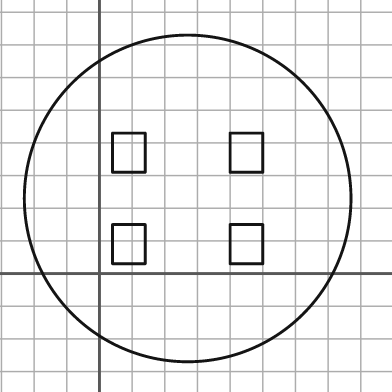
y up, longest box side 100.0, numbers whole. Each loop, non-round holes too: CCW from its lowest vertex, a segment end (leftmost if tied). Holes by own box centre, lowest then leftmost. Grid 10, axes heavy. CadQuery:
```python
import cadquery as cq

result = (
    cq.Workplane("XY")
    .moveTo(27.0, 23.0)
    .circle(50.0)
    .moveTo(4.0, 3.0)
    .lineTo(14.0, 3.0)
    .lineTo(14.0, 15.0)
    .lineTo(4.0, 15.0)
    .close()
    .moveTo(40.0, 3.0)
    .lineTo(50.0, 3.0)
    .lineTo(50.0, 15.0)
    .lineTo(40.0, 15.0)
    .close()
    .moveTo(4.0, 31.0)
    .lineTo(14.0, 31.0)
    .lineTo(14.0, 43.0)
    .lineTo(4.0, 43.0)
    .close()
    .moveTo(40.0, 31.0)
    .lineTo(50.0, 31.0)
    .lineTo(50.0, 43.0)
    .lineTo(40.0, 43.0)
    .close()
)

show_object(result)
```